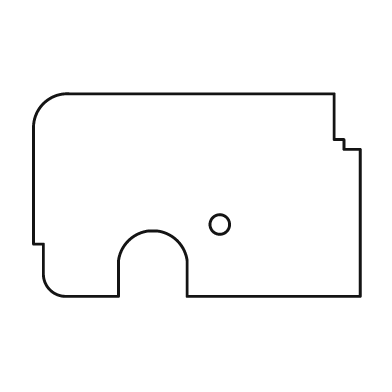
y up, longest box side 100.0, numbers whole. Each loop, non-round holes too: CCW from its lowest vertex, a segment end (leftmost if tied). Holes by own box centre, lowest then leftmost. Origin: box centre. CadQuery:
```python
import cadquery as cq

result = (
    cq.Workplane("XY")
    .moveTo(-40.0, -31.0)
    .lineTo(-24.0, -31.0)
    .lineTo(-24.0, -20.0)
    .threePointArc((-21.0, -14.0), (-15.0, -11.0))
    .lineTo(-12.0, -11.0)
    .threePointArc((-6.0, -14.0), (-3.0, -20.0))
    .lineTo(-3.0, -31.0)
    .lineTo(50.0, -31.0)
    .lineTo(50.0, 14.0)
    .lineTo(45.0, 14.0)
    .lineTo(45.0, 17.0)
    .lineTo(42.0, 17.0)
    .lineTo(42.0, 31.0)
    .lineTo(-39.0, 31.0)
    .threePointArc((-47.0, 28.0), (-50.0, 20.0))
    .lineTo(-50.0, -15.0)
    .lineTo(-47.0, -15.0)
    .lineTo(-47.0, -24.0)
    .threePointArc((-45.0, -29.0), (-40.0, -31.0))
    .close()
    .moveTo(7.0, -9.0)
    .circle(3.0)
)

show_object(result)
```